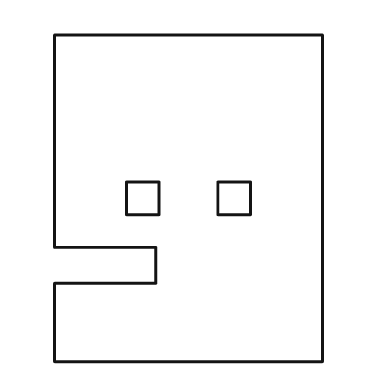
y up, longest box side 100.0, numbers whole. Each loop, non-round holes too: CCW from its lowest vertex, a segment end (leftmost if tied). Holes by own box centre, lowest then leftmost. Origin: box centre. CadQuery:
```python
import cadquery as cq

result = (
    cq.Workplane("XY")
    .moveTo(-41.0, -50.0)
    .lineTo(41.0, -50.0)
    .lineTo(41.0, 50.0)
    .lineTo(-41.0, 50.0)
    .lineTo(-41.0, -15.0)
    .lineTo(-10.0, -15.0)
    .lineTo(-10.0, -26.0)
    .lineTo(-41.0, -26.0)
    .close()
    .moveTo(-19.0, -5.0)
    .lineTo(-9.0, -5.0)
    .lineTo(-9.0, 5.0)
    .lineTo(-19.0, 5.0)
    .close()
    .moveTo(9.0, -5.0)
    .lineTo(19.0, -5.0)
    .lineTo(19.0, 5.0)
    .lineTo(9.0, 5.0)
    .close()
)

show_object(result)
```